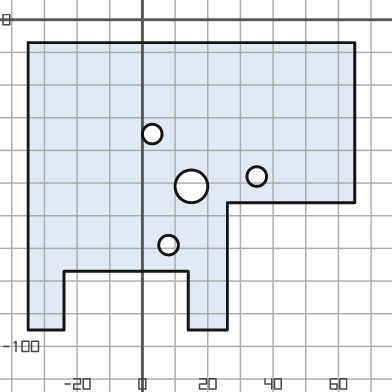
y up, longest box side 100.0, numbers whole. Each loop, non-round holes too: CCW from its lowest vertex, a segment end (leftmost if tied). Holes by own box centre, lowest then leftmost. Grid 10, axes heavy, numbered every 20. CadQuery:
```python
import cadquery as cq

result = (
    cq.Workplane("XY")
    .moveTo(-35.0, -95.0)
    .lineTo(-24.0, -95.0)
    .lineTo(-24.0, -77.0)
    .lineTo(14.0, -77.0)
    .lineTo(14.0, -95.0)
    .lineTo(26.0, -95.0)
    .lineTo(26.0, -56.0)
    .lineTo(65.0, -56.0)
    .lineTo(65.0, -7.0)
    .lineTo(-35.0, -7.0)
    .close()
    .moveTo(8.0, -69.0)
    .circle(3.0)
    .moveTo(15.0, -51.0)
    .circle(5.0)
    .moveTo(35.0, -48.0)
    .circle(3.0)
    .moveTo(3.0, -35.0)
    .circle(3.0)
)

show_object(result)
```